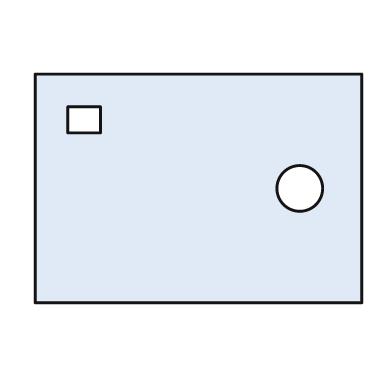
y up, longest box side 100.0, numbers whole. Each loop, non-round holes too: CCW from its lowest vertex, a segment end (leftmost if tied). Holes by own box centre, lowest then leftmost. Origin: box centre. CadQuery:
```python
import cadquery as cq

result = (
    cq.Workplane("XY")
    .moveTo(-50.0, -35.0)
    .lineTo(50.0, -35.0)
    .lineTo(50.0, 35.0)
    .lineTo(-50.0, 35.0)
    .close()
    .moveTo(31.0, 0.0)
    .circle(7.0)
    .moveTo(-40.0, 17.0)
    .lineTo(-30.0, 17.0)
    .lineTo(-30.0, 25.0)
    .lineTo(-40.0, 25.0)
    .close()
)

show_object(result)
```